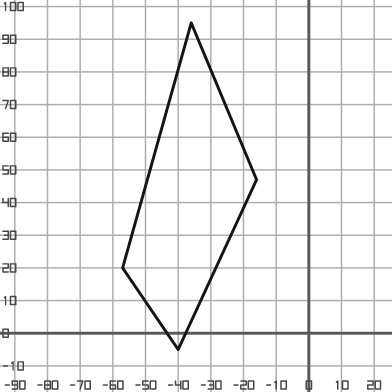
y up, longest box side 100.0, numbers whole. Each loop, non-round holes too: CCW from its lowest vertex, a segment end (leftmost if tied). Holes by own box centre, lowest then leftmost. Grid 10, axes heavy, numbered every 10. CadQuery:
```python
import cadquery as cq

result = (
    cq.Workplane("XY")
    .moveTo(-40.0, -5.0)
    .lineTo(-16.0, 47.0)
    .lineTo(-36.0, 95.0)
    .lineTo(-57.0, 20.0)
    .close()
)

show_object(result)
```